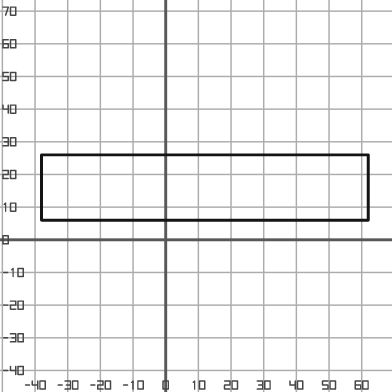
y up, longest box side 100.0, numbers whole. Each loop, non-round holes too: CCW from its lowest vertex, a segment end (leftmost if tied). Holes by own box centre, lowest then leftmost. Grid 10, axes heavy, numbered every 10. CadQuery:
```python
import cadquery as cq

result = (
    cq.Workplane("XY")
    .moveTo(-38.0, 6.0)
    .lineTo(62.0, 6.0)
    .lineTo(62.0, 26.0)
    .lineTo(-38.0, 26.0)
    .close()
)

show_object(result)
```